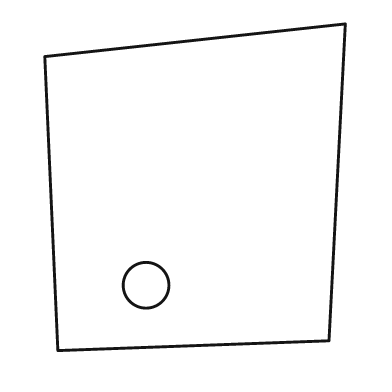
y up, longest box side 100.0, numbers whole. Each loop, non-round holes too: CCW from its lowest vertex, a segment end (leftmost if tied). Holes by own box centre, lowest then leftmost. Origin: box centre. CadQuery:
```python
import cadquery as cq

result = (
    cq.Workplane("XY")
    .moveTo(-42.0, -50.0)
    .lineTo(41.0, -47.0)
    .lineTo(46.0, 50.0)
    .lineTo(-46.0, 40.0)
    .close()
    .moveTo(-15.0, -30.0)
    .circle(7.0)
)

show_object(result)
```